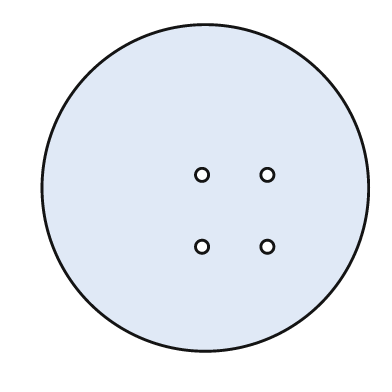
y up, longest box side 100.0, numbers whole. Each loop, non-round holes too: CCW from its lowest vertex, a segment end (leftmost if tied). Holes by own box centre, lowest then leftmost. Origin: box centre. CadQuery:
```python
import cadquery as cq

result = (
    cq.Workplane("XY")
    .moveTo(0.0, 0.0)
    .circle(50.0)
    .moveTo(-1.0, -18.0)
    .circle(2.0)
    .moveTo(19.0, -18.0)
    .circle(2.0)
    .moveTo(-1.0, 4.0)
    .circle(2.0)
    .moveTo(19.0, 4.0)
    .circle(2.0)
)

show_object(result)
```